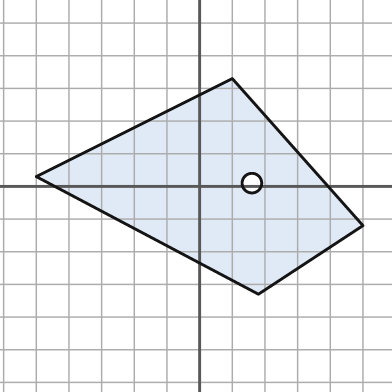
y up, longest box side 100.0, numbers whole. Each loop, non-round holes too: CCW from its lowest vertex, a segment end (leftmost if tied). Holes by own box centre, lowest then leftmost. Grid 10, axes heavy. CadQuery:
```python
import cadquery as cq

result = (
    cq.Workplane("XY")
    .moveTo(18.0, -33.0)
    .lineTo(50.0, -12.0)
    .lineTo(10.0, 33.0)
    .lineTo(-50.0, 3.0)
    .close()
    .moveTo(16.0, 1.0)
    .circle(3.0)
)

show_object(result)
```